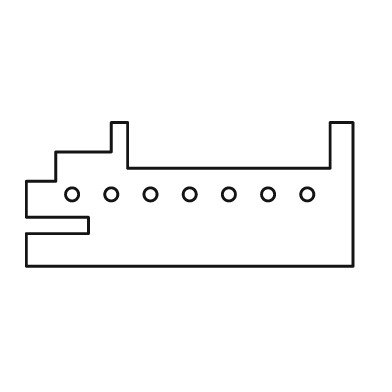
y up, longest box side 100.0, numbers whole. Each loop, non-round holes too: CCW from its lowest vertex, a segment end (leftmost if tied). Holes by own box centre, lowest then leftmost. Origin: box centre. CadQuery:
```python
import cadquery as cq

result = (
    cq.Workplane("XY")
    .moveTo(-50.0, -22.0)
    .lineTo(50.0, -22.0)
    .lineTo(50.0, 22.0)
    .lineTo(43.0, 22.0)
    .lineTo(43.0, 8.0)
    .lineTo(-19.0, 8.0)
    .lineTo(-19.0, 22.0)
    .lineTo(-24.0, 22.0)
    .lineTo(-24.0, 13.0)
    .lineTo(-41.0, 13.0)
    .lineTo(-41.0, 4.0)
    .lineTo(-50.0, 4.0)
    .lineTo(-50.0, -7.0)
    .lineTo(-31.0, -7.0)
    .lineTo(-31.0, -12.0)
    .lineTo(-50.0, -12.0)
    .close()
    .moveTo(-36.0, 0.0)
    .circle(2.0)
    .moveTo(-24.0, 0.0)
    .circle(2.0)
    .moveTo(-12.0, 0.0)
    .circle(2.0)
    .moveTo(0.0, 0.0)
    .circle(2.0)
    .moveTo(12.0, 0.0)
    .circle(2.0)
    .moveTo(24.0, 0.0)
    .circle(2.0)
    .moveTo(36.0, 0.0)
    .circle(2.0)
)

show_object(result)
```